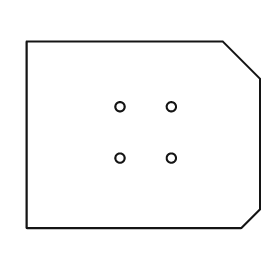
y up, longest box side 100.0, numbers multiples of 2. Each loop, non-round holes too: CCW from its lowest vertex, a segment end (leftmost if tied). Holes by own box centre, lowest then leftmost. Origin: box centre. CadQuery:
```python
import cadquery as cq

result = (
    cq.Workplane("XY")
    .moveTo(-50.0, -40.0)
    .lineTo(42.0, -40.0)
    .lineTo(50.0, -32.0)
    .lineTo(50.0, 24.0)
    .lineTo(34.0, 40.0)
    .lineTo(-50.0, 40.0)
    .close()
    .moveTo(-10.0, -10.0)
    .circle(2.0)
    .moveTo(12.0, -10.0)
    .circle(2.0)
    .moveTo(-10.0, 12.0)
    .circle(2.0)
    .moveTo(12.0, 12.0)
    .circle(2.0)
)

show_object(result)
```